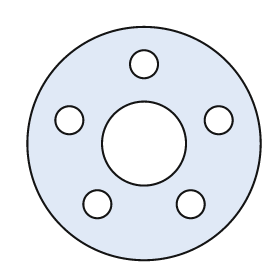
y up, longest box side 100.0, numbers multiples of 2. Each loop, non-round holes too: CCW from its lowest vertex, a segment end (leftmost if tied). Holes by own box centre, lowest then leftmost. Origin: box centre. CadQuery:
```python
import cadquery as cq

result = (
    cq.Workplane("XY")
    .moveTo(0.0, 0.0)
    .circle(50.0)
    .moveTo(-20.0, -26.0)
    .circle(6.0)
    .moveTo(20.0, -26.0)
    .circle(6.0)
    .moveTo(0.0, 0.0)
    .circle(18.0)
    .moveTo(-32.0, 10.0)
    .circle(6.0)
    .moveTo(32.0, 10.0)
    .circle(6.0)
    .moveTo(0.0, 34.0)
    .circle(6.0)
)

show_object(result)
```